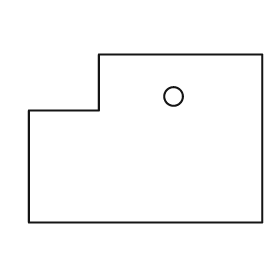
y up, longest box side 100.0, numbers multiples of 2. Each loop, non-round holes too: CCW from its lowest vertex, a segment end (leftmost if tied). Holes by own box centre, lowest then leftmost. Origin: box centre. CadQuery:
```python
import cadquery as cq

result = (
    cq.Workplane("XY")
    .moveTo(-50.0, -36.0)
    .lineTo(50.0, -36.0)
    .lineTo(50.0, 36.0)
    .lineTo(-20.0, 36.0)
    .lineTo(-20.0, 12.0)
    .lineTo(-50.0, 12.0)
    .close()
    .moveTo(12.0, 18.0)
    .circle(4.0)
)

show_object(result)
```